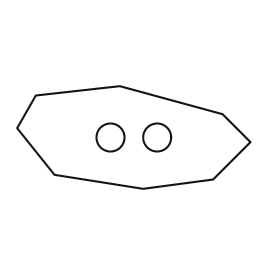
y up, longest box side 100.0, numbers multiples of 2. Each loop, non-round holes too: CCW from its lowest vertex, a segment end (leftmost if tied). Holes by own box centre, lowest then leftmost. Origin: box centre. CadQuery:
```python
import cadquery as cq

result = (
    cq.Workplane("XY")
    .moveTo(4.0, -22.0)
    .lineTo(34.0, -18.0)
    .lineTo(50.0, -2.0)
    .lineTo(38.0, 10.0)
    .lineTo(-6.0, 22.0)
    .lineTo(-42.0, 18.0)
    .lineTo(-50.0, 4.0)
    .lineTo(-34.0, -16.0)
    .close()
    .moveTo(-10.0, 0.0)
    .circle(6.0)
    .moveTo(10.0, 0.0)
    .circle(6.0)
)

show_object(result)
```